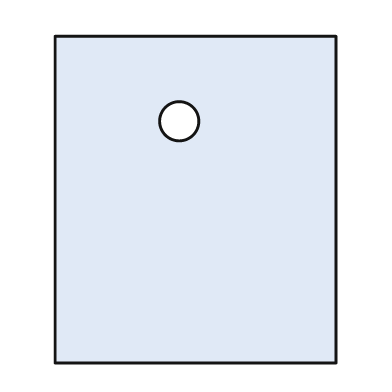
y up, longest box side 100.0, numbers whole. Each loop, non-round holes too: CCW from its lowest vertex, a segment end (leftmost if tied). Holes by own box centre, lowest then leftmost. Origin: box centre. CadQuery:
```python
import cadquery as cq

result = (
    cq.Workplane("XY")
    .moveTo(-43.0, -50.0)
    .lineTo(43.0, -50.0)
    .lineTo(43.0, 50.0)
    .lineTo(-43.0, 50.0)
    .close()
    .moveTo(-5.0, 24.0)
    .circle(6.0)
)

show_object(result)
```